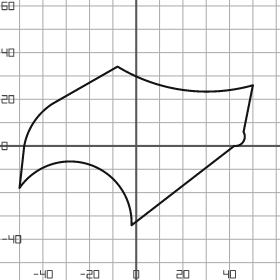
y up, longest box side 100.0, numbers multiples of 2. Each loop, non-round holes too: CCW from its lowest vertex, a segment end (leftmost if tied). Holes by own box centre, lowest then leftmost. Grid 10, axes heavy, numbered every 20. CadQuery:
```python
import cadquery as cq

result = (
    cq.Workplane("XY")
    .moveTo(-2.0, -34.0)
    .lineTo(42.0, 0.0)
    .threePointArc((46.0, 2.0), (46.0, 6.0))
    .lineTo(50.0, 26.0)
    .threePointArc((20.0, 24.0), (-8.0, 34.0))
    .lineTo(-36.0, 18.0)
    .threePointArc((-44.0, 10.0), (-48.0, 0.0))
    .lineTo(-50.0, -18.0)
    .threePointArc((-20.0, -8.0), (-2.0, -34.0))
    .close()
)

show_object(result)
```